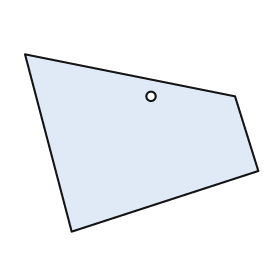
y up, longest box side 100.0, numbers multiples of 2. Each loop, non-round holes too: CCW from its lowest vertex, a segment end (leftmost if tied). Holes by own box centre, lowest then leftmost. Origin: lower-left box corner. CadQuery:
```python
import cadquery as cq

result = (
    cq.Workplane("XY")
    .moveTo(20.0, 0.0)
    .lineTo(100.0, 26.0)
    .lineTo(90.0, 58.0)
    .lineTo(0.0, 76.0)
    .close()
    .moveTo(54.0, 58.0)
    .circle(2.0)
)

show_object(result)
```